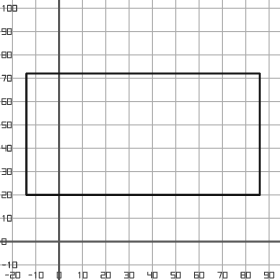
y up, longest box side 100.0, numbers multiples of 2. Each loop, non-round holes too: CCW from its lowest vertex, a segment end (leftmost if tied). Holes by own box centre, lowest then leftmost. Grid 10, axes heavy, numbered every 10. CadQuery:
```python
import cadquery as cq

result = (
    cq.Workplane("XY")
    .moveTo(-14.0, 20.0)
    .lineTo(86.0, 20.0)
    .lineTo(86.0, 72.0)
    .lineTo(-14.0, 72.0)
    .close()
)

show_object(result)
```